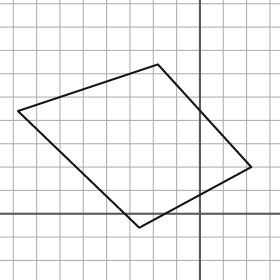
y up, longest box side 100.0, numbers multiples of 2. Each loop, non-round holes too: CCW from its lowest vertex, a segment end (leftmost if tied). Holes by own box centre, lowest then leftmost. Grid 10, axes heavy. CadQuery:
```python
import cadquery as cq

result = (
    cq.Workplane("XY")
    .moveTo(-26.0, -6.0)
    .lineTo(22.0, 20.0)
    .lineTo(-18.0, 64.0)
    .lineTo(-78.0, 44.0)
    .close()
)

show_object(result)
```